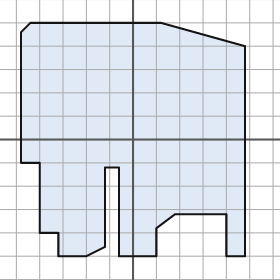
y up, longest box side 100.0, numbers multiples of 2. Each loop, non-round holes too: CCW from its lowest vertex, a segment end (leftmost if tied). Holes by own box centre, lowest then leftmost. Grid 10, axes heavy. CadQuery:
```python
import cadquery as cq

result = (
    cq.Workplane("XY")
    .moveTo(-32.0, -50.0)
    .lineTo(-20.0, -50.0)
    .lineTo(-12.0, -46.0)
    .lineTo(-12.0, -12.0)
    .lineTo(-6.0, -12.0)
    .lineTo(-6.0, -50.0)
    .lineTo(10.0, -50.0)
    .lineTo(10.0, -38.0)
    .lineTo(18.0, -32.0)
    .lineTo(40.0, -32.0)
    .lineTo(40.0, -50.0)
    .lineTo(48.0, -50.0)
    .lineTo(48.0, 40.0)
    .lineTo(12.0, 50.0)
    .lineTo(-44.0, 50.0)
    .lineTo(-48.0, 46.0)
    .lineTo(-48.0, -10.0)
    .lineTo(-40.0, -10.0)
    .lineTo(-40.0, -40.0)
    .lineTo(-32.0, -40.0)
    .close()
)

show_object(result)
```